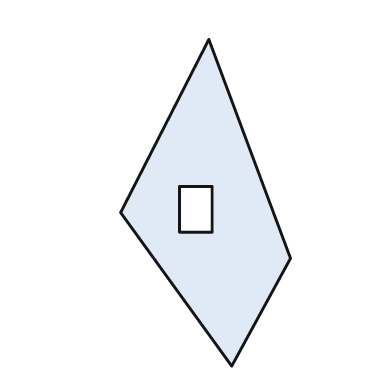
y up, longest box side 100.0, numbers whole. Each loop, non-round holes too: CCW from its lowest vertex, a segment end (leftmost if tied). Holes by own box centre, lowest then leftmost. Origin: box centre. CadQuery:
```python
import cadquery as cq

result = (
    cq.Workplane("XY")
    .moveTo(8.0, -50.0)
    .lineTo(26.0, -17.0)
    .lineTo(1.0, 50.0)
    .lineTo(-26.0, -3.0)
    .close()
    .moveTo(-8.0, -9.0)
    .lineTo(2.0, -9.0)
    .lineTo(2.0, 5.0)
    .lineTo(-8.0, 5.0)
    .close()
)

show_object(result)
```